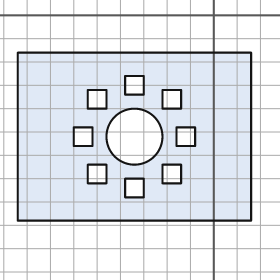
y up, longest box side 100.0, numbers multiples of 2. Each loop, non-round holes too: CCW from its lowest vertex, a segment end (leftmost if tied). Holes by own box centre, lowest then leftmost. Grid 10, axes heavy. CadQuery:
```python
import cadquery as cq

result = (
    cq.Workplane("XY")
    .moveTo(-84.0, -88.0)
    .lineTo(16.0, -88.0)
    .lineTo(16.0, -16.0)
    .lineTo(-84.0, -16.0)
    .close()
    .moveTo(-38.0, -78.0)
    .lineTo(-30.0, -78.0)
    .lineTo(-30.0, -70.0)
    .lineTo(-38.0, -70.0)
    .close()
    .moveTo(-54.0, -72.0)
    .lineTo(-46.0, -72.0)
    .lineTo(-46.0, -64.0)
    .lineTo(-54.0, -64.0)
    .close()
    .moveTo(-22.0, -72.0)
    .lineTo(-14.0, -72.0)
    .lineTo(-14.0, -64.0)
    .lineTo(-22.0, -64.0)
    .close()
    .moveTo(-60.0, -56.0)
    .lineTo(-52.0, -56.0)
    .lineTo(-52.0, -48.0)
    .lineTo(-60.0, -48.0)
    .close()
    .moveTo(-34.0, -52.0)
    .circle(12.0)
    .moveTo(-16.0, -56.0)
    .lineTo(-8.0, -56.0)
    .lineTo(-8.0, -48.0)
    .lineTo(-16.0, -48.0)
    .close()
    .moveTo(-54.0, -40.0)
    .lineTo(-46.0, -40.0)
    .lineTo(-46.0, -32.0)
    .lineTo(-54.0, -32.0)
    .close()
    .moveTo(-22.0, -40.0)
    .lineTo(-14.0, -40.0)
    .lineTo(-14.0, -32.0)
    .lineTo(-22.0, -32.0)
    .close()
    .moveTo(-38.0, -34.0)
    .lineTo(-30.0, -34.0)
    .lineTo(-30.0, -26.0)
    .lineTo(-38.0, -26.0)
    .close()
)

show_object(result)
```